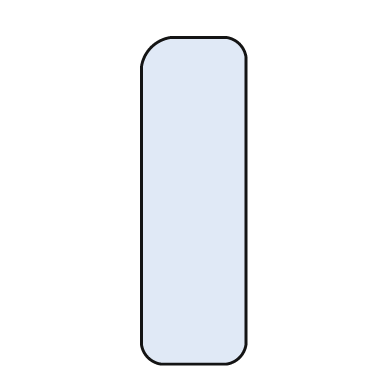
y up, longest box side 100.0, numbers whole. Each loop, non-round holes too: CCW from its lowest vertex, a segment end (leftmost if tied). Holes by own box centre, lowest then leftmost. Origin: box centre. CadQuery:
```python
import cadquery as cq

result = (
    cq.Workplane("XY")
    .moveTo(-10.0, -50.0)
    .lineTo(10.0, -50.0)
    .threePointArc((14.0, -48.0), (16.0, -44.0))
    .lineTo(16.0, 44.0)
    .threePointArc((14.0, 48.0), (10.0, 50.0))
    .lineTo(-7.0, 50.0)
    .threePointArc((-13.0, 47.0), (-16.0, 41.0))
    .lineTo(-16.0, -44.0)
    .threePointArc((-14.0, -48.0), (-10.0, -50.0))
    .close()
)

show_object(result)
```